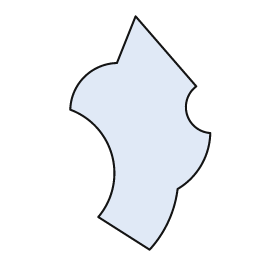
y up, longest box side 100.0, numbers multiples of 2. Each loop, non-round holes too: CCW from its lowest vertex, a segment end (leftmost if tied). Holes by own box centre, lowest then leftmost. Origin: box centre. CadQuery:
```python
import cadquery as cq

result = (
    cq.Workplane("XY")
    .moveTo(4.0, -50.0)
    .threePointArc((12.0, -38.0), (16.0, -24.0))
    .threePointArc((26.0, -14.0), (30.0, 0.0))
    .threePointArc((20.0, 8.0), (24.0, 20.0))
    .lineTo(-2.0, 50.0)
    .lineTo(-10.0, 30.0)
    .threePointArc((-24.0, 24.0), (-30.0, 10.0))
    .threePointArc((-12.0, -10.0), (-18.0, -36.0))
    .close()
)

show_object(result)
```